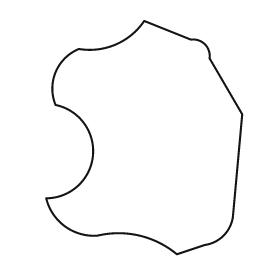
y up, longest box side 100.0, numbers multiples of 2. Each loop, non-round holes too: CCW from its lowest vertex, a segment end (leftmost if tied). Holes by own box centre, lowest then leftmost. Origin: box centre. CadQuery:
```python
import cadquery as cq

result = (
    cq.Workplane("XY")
    .moveTo(14.0, -50.0)
    .lineTo(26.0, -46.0)
    .threePointArc((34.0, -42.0), (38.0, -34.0))
    .lineTo(42.0, 10.0)
    .lineTo(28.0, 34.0)
    .threePointArc((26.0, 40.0), (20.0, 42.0))
    .lineTo(0.0, 50.0)
    .threePointArc((-12.0, 40.0), (-28.0, 38.0))
    .threePointArc((-38.0, 28.0), (-38.0, 14.0))
    .threePointArc((-22.0, -8.0), (-42.0, -26.0))
    .threePointArc((-34.0, -38.0), (-20.0, -42.0))
    .threePointArc((-2.0, -42.0), (14.0, -50.0))
    .close()
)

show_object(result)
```